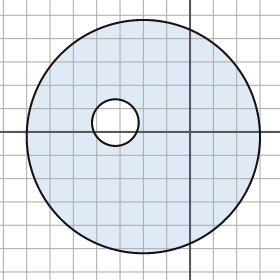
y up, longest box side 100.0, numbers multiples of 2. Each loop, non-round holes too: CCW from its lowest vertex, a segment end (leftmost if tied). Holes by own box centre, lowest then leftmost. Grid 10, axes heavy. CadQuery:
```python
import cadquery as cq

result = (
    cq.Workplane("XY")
    .moveTo(-20.0, -2.0)
    .circle(50.0)
    .moveTo(-32.0, 4.0)
    .circle(10.0)
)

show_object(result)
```